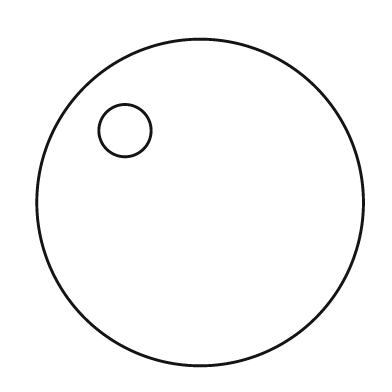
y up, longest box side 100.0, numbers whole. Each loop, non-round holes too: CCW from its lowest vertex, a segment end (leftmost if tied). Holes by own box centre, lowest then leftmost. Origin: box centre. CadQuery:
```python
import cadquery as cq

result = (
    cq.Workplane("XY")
    .moveTo(0.0, 0.0)
    .circle(50.0)
    .moveTo(-23.0, 22.0)
    .circle(8.0)
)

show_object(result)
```